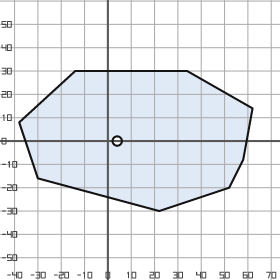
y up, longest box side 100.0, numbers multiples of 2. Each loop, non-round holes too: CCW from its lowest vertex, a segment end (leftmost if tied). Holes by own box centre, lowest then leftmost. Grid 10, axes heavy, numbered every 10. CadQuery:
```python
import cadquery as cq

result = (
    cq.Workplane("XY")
    .moveTo(22.0, -30.0)
    .lineTo(52.0, -20.0)
    .lineTo(58.0, -8.0)
    .lineTo(62.0, 14.0)
    .lineTo(34.0, 30.0)
    .lineTo(-14.0, 30.0)
    .lineTo(-38.0, 8.0)
    .lineTo(-30.0, -16.0)
    .close()
    .moveTo(4.0, 0.0)
    .circle(2.0)
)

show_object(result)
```